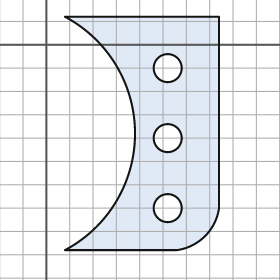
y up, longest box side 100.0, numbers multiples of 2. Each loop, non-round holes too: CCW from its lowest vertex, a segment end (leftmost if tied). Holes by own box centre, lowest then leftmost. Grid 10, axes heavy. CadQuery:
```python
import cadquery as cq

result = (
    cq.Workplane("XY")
    .moveTo(8.0, -88.0)
    .lineTo(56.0, -88.0)
    .threePointArc((68.0, -82.0), (74.0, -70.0))
    .lineTo(74.0, 12.0)
    .lineTo(8.0, 12.0)
    .threePointArc((38.0, -38.0), (8.0, -88.0))
    .close()
    .moveTo(52.0, -70.0)
    .circle(6.0)
    .moveTo(52.0, -40.0)
    .circle(6.0)
    .moveTo(52.0, -10.0)
    .circle(6.0)
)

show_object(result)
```